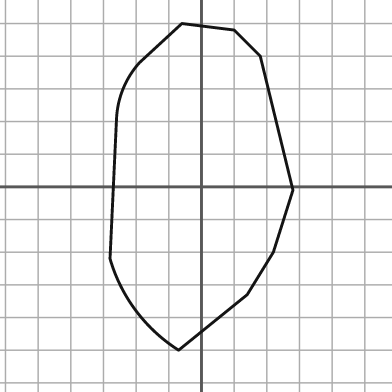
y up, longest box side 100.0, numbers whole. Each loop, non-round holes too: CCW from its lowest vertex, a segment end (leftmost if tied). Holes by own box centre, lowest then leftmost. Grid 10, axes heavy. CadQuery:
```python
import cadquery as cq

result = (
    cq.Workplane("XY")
    .moveTo(-7.0, -50.0)
    .lineTo(14.0, -33.0)
    .lineTo(22.0, -20.0)
    .lineTo(28.0, -1.0)
    .lineTo(18.0, 40.0)
    .lineTo(10.0, 48.0)
    .lineTo(-6.0, 50.0)
    .lineTo(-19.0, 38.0)
    .threePointArc((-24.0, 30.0), (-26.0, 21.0))
    .lineTo(-28.0, -22.0)
    .threePointArc((-20.0, -38.0), (-7.0, -50.0))
    .close()
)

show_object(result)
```